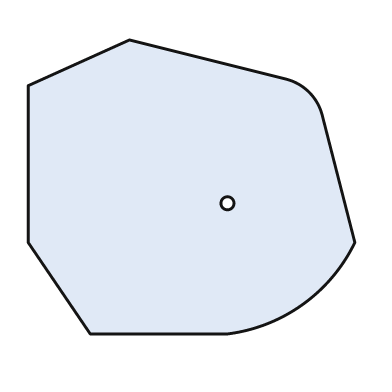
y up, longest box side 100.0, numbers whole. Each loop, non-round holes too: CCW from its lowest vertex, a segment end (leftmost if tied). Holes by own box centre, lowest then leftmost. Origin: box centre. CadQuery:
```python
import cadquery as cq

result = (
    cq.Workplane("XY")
    .moveTo(-31.0, -45.0)
    .lineTo(11.0, -45.0)
    .threePointArc((34.0, -36.0), (50.0, -17.0))
    .lineTo(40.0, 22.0)
    .threePointArc((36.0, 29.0), (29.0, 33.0))
    .lineTo(-19.0, 45.0)
    .lineTo(-50.0, 31.0)
    .lineTo(-50.0, -17.0)
    .close()
    .moveTo(11.0, -5.0)
    .circle(2.0)
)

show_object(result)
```